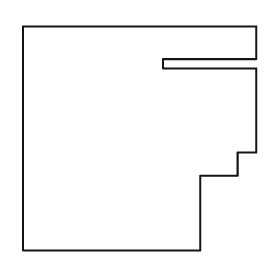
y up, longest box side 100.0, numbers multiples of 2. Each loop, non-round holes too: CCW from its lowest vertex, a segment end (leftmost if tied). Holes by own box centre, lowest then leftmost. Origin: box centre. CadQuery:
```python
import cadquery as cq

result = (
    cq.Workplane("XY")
    .moveTo(-50.0, -48.0)
    .lineTo(26.0, -48.0)
    .lineTo(26.0, -16.0)
    .lineTo(42.0, -16.0)
    .lineTo(42.0, -6.0)
    .lineTo(50.0, -6.0)
    .lineTo(50.0, 30.0)
    .lineTo(10.0, 30.0)
    .lineTo(10.0, 34.0)
    .lineTo(50.0, 34.0)
    .lineTo(50.0, 48.0)
    .lineTo(-50.0, 48.0)
    .close()
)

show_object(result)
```